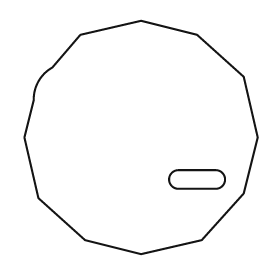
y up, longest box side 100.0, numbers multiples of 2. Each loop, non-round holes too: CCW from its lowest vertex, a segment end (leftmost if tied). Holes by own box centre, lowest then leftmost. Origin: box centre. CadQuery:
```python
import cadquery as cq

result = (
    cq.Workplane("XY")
    .moveTo(0.0, -50.0)
    .lineTo(26.0, -44.0)
    .lineTo(44.0, -24.0)
    .lineTo(50.0, 0.0)
    .lineTo(44.0, 26.0)
    .lineTo(24.0, 44.0)
    .lineTo(0.0, 50.0)
    .lineTo(-26.0, 44.0)
    .lineTo(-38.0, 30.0)
    .threePointArc((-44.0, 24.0), (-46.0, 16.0))
    .lineTo(-50.0, 0.0)
    .lineTo(-44.0, -26.0)
    .lineTo(-24.0, -44.0)
    .close()
    .moveTo(16.0, -22.0)
    .lineTo(32.0, -22.0)
    .threePointArc((36.0, -18.0), (32.0, -14.0))
    .lineTo(16.0, -14.0)
    .threePointArc((12.0, -18.0), (16.0, -22.0))
    .close()
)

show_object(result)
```